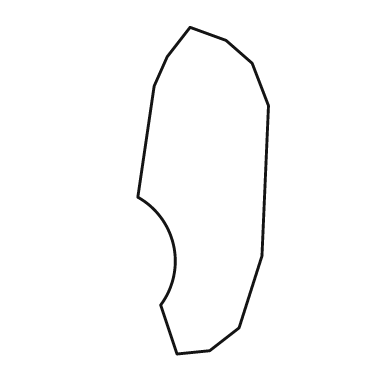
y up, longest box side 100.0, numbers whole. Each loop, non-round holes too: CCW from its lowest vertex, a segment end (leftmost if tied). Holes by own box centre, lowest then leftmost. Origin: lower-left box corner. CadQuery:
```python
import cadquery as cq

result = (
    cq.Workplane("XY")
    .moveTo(12.0, 0.0)
    .lineTo(22.0, 1.0)
    .lineTo(31.0, 8.0)
    .lineTo(38.0, 30.0)
    .lineTo(40.0, 76.0)
    .lineTo(35.0, 89.0)
    .lineTo(27.0, 96.0)
    .lineTo(16.0, 100.0)
    .lineTo(9.0, 91.0)
    .lineTo(5.0, 82.0)
    .lineTo(0.0, 48.0)
    .threePointArc((11.0, 33.0), (7.0, 15.0))
    .close()
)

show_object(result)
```